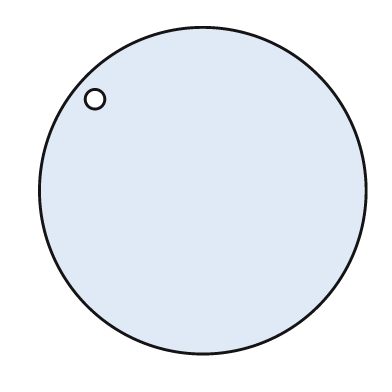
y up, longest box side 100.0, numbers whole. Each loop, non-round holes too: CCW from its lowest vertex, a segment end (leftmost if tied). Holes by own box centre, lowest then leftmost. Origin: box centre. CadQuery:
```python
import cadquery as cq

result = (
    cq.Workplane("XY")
    .moveTo(0.0, 0.0)
    .circle(50.0)
    .moveTo(-33.0, 28.0)
    .circle(3.0)
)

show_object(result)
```